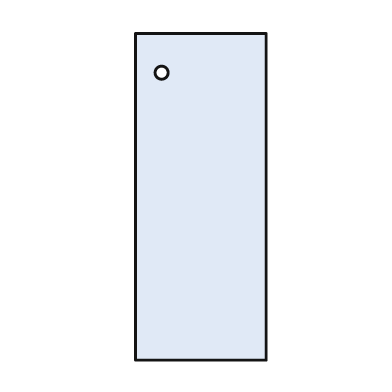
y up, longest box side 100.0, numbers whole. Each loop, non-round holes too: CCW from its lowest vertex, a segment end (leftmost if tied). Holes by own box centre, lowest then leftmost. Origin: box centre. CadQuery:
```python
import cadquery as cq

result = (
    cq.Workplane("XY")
    .moveTo(-20.0, -50.0)
    .lineTo(20.0, -50.0)
    .lineTo(20.0, 50.0)
    .lineTo(-20.0, 50.0)
    .close()
    .moveTo(-12.0, 38.0)
    .circle(2.0)
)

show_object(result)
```